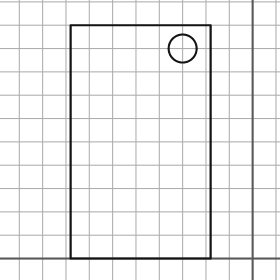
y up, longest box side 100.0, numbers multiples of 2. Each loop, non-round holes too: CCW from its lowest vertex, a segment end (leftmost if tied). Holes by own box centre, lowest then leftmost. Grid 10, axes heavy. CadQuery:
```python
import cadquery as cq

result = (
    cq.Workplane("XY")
    .moveTo(-78.0, 0.0)
    .lineTo(-18.0, 0.0)
    .lineTo(-18.0, 100.0)
    .lineTo(-78.0, 100.0)
    .close()
    .moveTo(-30.0, 90.0)
    .circle(6.0)
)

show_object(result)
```